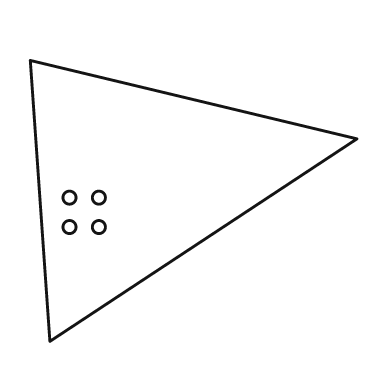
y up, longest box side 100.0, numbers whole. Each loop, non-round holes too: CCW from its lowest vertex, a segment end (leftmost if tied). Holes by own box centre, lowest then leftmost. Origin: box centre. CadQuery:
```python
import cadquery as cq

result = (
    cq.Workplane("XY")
    .moveTo(-44.0, -43.0)
    .lineTo(50.0, 19.0)
    .lineTo(-50.0, 43.0)
    .close()
    .moveTo(-38.0, -8.0)
    .circle(2.0)
    .moveTo(-29.0, -8.0)
    .circle(2.0)
    .moveTo(-38.0, 1.0)
    .circle(2.0)
    .moveTo(-29.0, 1.0)
    .circle(2.0)
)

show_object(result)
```